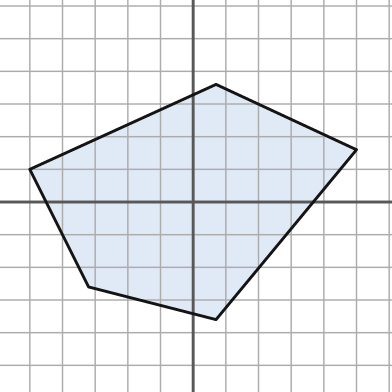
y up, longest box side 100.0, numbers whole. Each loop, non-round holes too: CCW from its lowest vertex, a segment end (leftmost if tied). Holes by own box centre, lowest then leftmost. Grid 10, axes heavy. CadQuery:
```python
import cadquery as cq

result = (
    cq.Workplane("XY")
    .moveTo(7.0, -36.0)
    .lineTo(50.0, 16.0)
    .lineTo(7.0, 36.0)
    .lineTo(-50.0, 10.0)
    .lineTo(-32.0, -26.0)
    .close()
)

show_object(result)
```